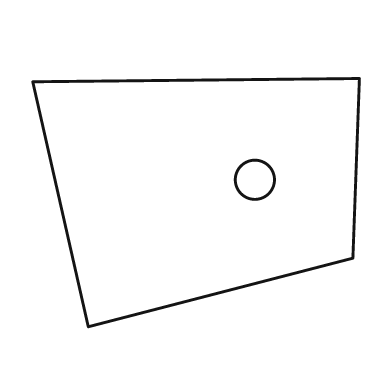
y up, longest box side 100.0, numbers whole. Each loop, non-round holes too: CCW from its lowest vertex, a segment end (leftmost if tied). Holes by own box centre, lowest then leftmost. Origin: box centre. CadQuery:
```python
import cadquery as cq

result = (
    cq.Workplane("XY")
    .moveTo(-33.0, -38.0)
    .lineTo(48.0, -17.0)
    .lineTo(50.0, 38.0)
    .lineTo(-50.0, 37.0)
    .close()
    .moveTo(18.0, 7.0)
    .circle(6.0)
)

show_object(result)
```